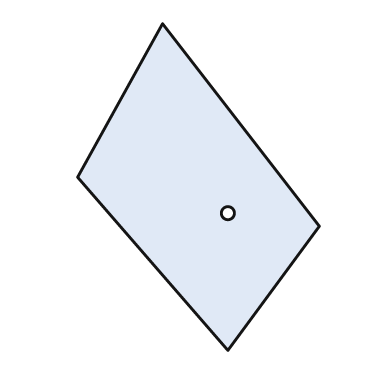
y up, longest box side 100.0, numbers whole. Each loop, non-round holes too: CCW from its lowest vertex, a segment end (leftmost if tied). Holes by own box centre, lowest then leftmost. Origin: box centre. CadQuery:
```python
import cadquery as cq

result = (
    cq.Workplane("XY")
    .moveTo(9.0, -50.0)
    .lineTo(37.0, -12.0)
    .lineTo(-11.0, 50.0)
    .lineTo(-37.0, 3.0)
    .close()
    .moveTo(9.0, -8.0)
    .circle(2.0)
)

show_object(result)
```